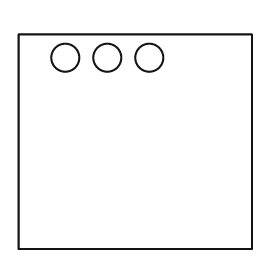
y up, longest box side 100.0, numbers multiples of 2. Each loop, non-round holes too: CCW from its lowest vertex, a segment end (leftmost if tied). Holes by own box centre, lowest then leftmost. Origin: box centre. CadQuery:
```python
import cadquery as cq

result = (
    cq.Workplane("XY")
    .moveTo(-50.0, -46.0)
    .lineTo(50.0, -46.0)
    .lineTo(50.0, 46.0)
    .lineTo(-50.0, 46.0)
    .close()
    .moveTo(-30.0, 36.0)
    .circle(6.0)
    .moveTo(-12.0, 36.0)
    .circle(6.0)
    .moveTo(6.0, 36.0)
    .circle(6.0)
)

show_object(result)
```